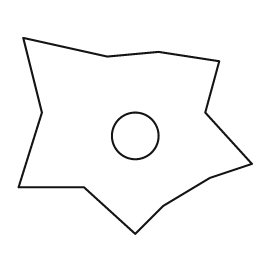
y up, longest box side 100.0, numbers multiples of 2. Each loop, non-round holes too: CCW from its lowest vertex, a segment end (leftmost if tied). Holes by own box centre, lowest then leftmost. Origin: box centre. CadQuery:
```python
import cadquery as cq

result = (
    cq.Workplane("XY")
    .moveTo(0.0, -42.0)
    .lineTo(12.0, -30.0)
    .lineTo(32.0, -18.0)
    .lineTo(50.0, -12.0)
    .lineTo(30.0, 10.0)
    .lineTo(36.0, 32.0)
    .lineTo(10.0, 36.0)
    .lineTo(-12.0, 34.0)
    .lineTo(-48.0, 42.0)
    .lineTo(-40.0, 10.0)
    .lineTo(-50.0, -22.0)
    .lineTo(-22.0, -22.0)
    .close()
    .moveTo(0.0, 0.0)
    .circle(10.0)
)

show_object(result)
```